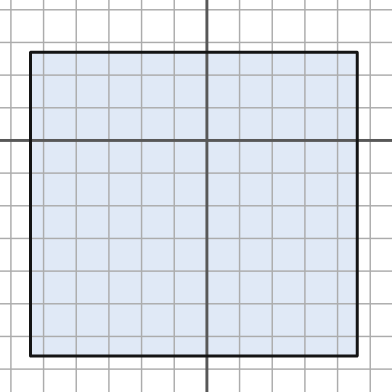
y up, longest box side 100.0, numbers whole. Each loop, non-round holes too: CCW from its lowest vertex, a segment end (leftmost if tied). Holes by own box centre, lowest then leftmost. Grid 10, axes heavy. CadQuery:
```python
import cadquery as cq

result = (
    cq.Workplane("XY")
    .moveTo(-54.0, -66.0)
    .lineTo(46.0, -66.0)
    .lineTo(46.0, 27.0)
    .lineTo(-54.0, 27.0)
    .close()
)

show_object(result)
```